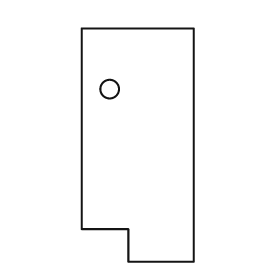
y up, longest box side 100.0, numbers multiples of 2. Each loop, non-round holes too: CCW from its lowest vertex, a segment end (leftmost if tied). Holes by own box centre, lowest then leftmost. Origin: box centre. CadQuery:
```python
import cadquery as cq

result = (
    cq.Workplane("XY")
    .moveTo(-4.0, -50.0)
    .lineTo(24.0, -50.0)
    .lineTo(24.0, 50.0)
    .lineTo(-24.0, 50.0)
    .lineTo(-24.0, -36.0)
    .lineTo(-4.0, -36.0)
    .close()
    .moveTo(-12.0, 24.0)
    .circle(4.0)
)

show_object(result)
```